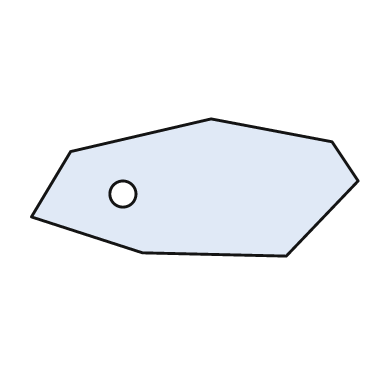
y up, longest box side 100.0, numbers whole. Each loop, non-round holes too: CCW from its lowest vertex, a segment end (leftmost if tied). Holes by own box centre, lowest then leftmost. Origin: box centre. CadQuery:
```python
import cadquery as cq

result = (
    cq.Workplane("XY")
    .moveTo(28.0, -21.0)
    .lineTo(50.0, 2.0)
    .lineTo(42.0, 14.0)
    .lineTo(5.0, 21.0)
    .lineTo(-38.0, 11.0)
    .lineTo(-50.0, -9.0)
    .lineTo(-16.0, -20.0)
    .close()
    .moveTo(-22.0, -2.0)
    .circle(4.0)
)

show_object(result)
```